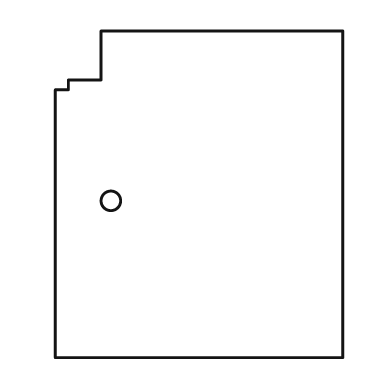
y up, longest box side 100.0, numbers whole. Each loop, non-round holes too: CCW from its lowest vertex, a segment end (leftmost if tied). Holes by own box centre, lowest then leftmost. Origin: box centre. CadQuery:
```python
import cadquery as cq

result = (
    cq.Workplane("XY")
    .moveTo(-44.0, -50.0)
    .lineTo(44.0, -50.0)
    .lineTo(44.0, 50.0)
    .lineTo(-30.0, 50.0)
    .lineTo(-30.0, 35.0)
    .lineTo(-40.0, 35.0)
    .lineTo(-40.0, 32.0)
    .lineTo(-44.0, 32.0)
    .close()
    .moveTo(-27.0, -2.0)
    .circle(3.0)
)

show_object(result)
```